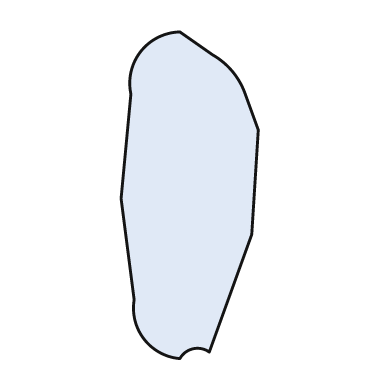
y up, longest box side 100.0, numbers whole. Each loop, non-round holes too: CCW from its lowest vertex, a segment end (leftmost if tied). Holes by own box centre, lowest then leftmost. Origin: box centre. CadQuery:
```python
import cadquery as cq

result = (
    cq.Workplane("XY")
    .moveTo(-3.0, -50.0)
    .threePointArc((1.0, -47.0), (6.0, -48.0))
    .lineTo(19.0, -12.0)
    .lineTo(21.0, 20.0)
    .lineTo(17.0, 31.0)
    .threePointArc((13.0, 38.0), (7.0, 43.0))
    .lineTo(-3.0, 50.0)
    .threePointArc((-15.0, 44.0), (-18.0, 31.0))
    .lineTo(-21.0, -1.0)
    .lineTo(-17.0, -32.0)
    .threePointArc((-14.0, -44.0), (-3.0, -50.0))
    .close()
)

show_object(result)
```